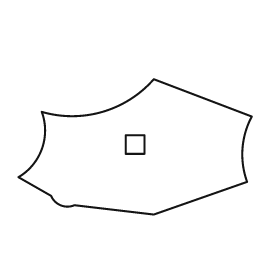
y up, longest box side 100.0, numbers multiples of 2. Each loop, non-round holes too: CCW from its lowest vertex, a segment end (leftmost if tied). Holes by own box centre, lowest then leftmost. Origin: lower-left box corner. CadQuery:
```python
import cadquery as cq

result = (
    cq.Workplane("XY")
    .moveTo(58.0, 0.0)
    .lineTo(98.0, 14.0)
    .threePointArc((96.0, 28.0), (100.0, 42.0))
    .lineTo(58.0, 58.0)
    .threePointArc((36.0, 44.0), (10.0, 44.0))
    .threePointArc((10.0, 28.0), (0.0, 16.0))
    .lineTo(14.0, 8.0)
    .threePointArc((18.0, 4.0), (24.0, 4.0))
    .close()
    .moveTo(46.0, 26.0)
    .lineTo(54.0, 26.0)
    .lineTo(54.0, 34.0)
    .lineTo(46.0, 34.0)
    .close()
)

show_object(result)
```